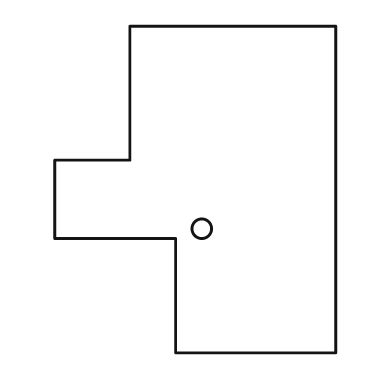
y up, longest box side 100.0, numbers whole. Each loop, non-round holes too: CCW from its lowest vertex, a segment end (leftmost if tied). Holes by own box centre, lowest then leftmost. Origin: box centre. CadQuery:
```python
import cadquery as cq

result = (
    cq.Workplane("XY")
    .moveTo(-6.0, -50.0)
    .lineTo(43.0, -50.0)
    .lineTo(43.0, 50.0)
    .lineTo(-20.0, 50.0)
    .lineTo(-20.0, 9.0)
    .lineTo(-43.0, 9.0)
    .lineTo(-43.0, -15.0)
    .lineTo(-6.0, -15.0)
    .close()
    .moveTo(2.0, -12.0)
    .circle(3.0)
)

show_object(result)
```